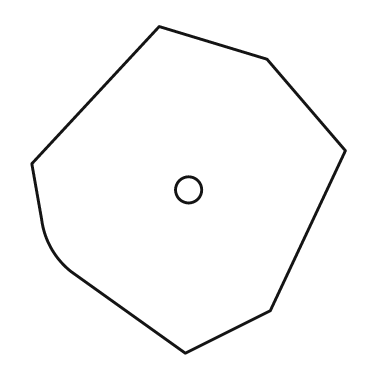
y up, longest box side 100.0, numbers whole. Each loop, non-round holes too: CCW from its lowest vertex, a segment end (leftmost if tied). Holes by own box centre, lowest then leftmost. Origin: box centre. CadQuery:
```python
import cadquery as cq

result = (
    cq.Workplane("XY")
    .moveTo(-1.0, -50.0)
    .lineTo(25.0, -37.0)
    .lineTo(48.0, 12.0)
    .lineTo(24.0, 40.0)
    .lineTo(-9.0, 50.0)
    .lineTo(-48.0, 8.0)
    .lineTo(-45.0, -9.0)
    .threePointArc((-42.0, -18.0), (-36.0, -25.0))
    .close()
    .moveTo(0.0, 0.0)
    .circle(4.0)
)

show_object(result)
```